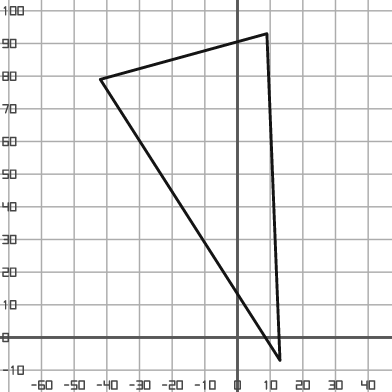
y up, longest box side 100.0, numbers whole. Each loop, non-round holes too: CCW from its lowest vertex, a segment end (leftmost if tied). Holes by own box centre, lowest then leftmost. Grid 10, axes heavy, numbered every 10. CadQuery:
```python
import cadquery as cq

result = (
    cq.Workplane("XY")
    .moveTo(13.0, -7.0)
    .lineTo(9.0, 93.0)
    .lineTo(-42.0, 79.0)
    .close()
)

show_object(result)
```